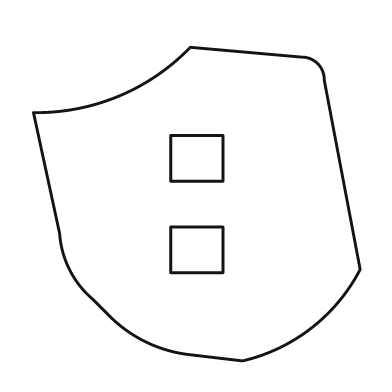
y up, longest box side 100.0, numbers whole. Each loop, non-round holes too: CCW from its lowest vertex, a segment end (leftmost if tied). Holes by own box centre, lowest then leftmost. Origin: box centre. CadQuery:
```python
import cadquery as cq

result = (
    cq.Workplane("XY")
    .moveTo(14.0, -48.0)
    .threePointArc((35.0, -38.0), (50.0, -20.0))
    .lineTo(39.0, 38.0)
    .threePointArc((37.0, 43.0), (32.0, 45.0))
    .lineTo(-2.0, 48.0)
    .threePointArc((-24.0, 33.0), (-50.0, 28.0))
    .lineTo(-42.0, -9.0)
    .threePointArc((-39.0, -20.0), (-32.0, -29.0))
    .lineTo(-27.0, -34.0)
    .threePointArc((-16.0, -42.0), (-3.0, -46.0))
    .close()
    .moveTo(-8.0, -21.0)
    .lineTo(8.0, -21.0)
    .lineTo(8.0, -7.0)
    .lineTo(-8.0, -7.0)
    .close()
    .moveTo(-8.0, 7.0)
    .lineTo(8.0, 7.0)
    .lineTo(8.0, 21.0)
    .lineTo(-8.0, 21.0)
    .close()
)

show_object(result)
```